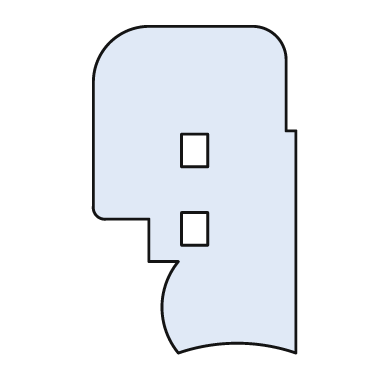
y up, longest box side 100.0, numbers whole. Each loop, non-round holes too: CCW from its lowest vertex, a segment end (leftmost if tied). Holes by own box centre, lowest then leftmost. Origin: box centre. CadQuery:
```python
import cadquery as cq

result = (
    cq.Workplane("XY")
    .moveTo(-5.0, -50.0)
    .threePointArc((13.0, -47.0), (31.0, -50.0))
    .lineTo(31.0, 18.0)
    .lineTo(28.0, 18.0)
    .lineTo(28.0, 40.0)
    .threePointArc((25.0, 47.0), (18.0, 50.0))
    .lineTo(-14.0, 50.0)
    .threePointArc((-26.0, 45.0), (-31.0, 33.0))
    .lineTo(-31.0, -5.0)
    .threePointArc((-30.0, -8.0), (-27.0, -9.0))
    .lineTo(-14.0, -9.0)
    .lineTo(-14.0, -22.0)
    .lineTo(-5.0, -22.0)
    .threePointArc((-10.0, -36.0), (-5.0, -50.0))
    .close()
    .moveTo(-4.0, -17.0)
    .lineTo(4.0, -17.0)
    .lineTo(4.0, -7.0)
    .lineTo(-4.0, -7.0)
    .close()
    .moveTo(-4.0, 7.0)
    .lineTo(4.0, 7.0)
    .lineTo(4.0, 17.0)
    .lineTo(-4.0, 17.0)
    .close()
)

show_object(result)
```